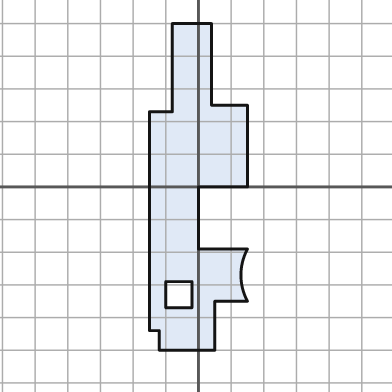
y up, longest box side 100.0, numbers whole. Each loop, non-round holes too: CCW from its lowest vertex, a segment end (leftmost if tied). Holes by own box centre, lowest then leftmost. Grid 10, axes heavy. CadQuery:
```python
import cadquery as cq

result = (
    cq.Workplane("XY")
    .moveTo(-12.0, -50.0)
    .lineTo(5.0, -50.0)
    .lineTo(5.0, -35.0)
    .lineTo(15.0, -35.0)
    .threePointArc((13.0, -27.0), (15.0, -19.0))
    .lineTo(0.0, -19.0)
    .lineTo(0.0, 0.0)
    .lineTo(15.0, 0.0)
    .lineTo(15.0, 25.0)
    .lineTo(4.0, 25.0)
    .lineTo(4.0, 50.0)
    .lineTo(-8.0, 50.0)
    .lineTo(-8.0, 23.0)
    .lineTo(-15.0, 23.0)
    .lineTo(-15.0, -44.0)
    .lineTo(-12.0, -44.0)
    .close()
    .moveTo(-10.0, -37.0)
    .lineTo(-2.0, -37.0)
    .lineTo(-2.0, -29.0)
    .lineTo(-10.0, -29.0)
    .close()
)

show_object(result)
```